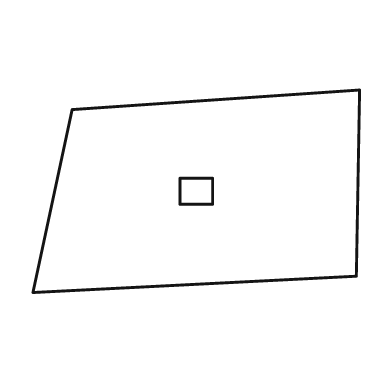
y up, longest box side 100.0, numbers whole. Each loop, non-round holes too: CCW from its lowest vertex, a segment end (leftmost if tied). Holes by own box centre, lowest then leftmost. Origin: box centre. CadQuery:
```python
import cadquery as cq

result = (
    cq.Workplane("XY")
    .moveTo(-50.0, -31.0)
    .lineTo(49.0, -26.0)
    .lineTo(50.0, 31.0)
    .lineTo(-38.0, 25.0)
    .close()
    .moveTo(-5.0, -4.0)
    .lineTo(5.0, -4.0)
    .lineTo(5.0, 4.0)
    .lineTo(-5.0, 4.0)
    .close()
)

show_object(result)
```